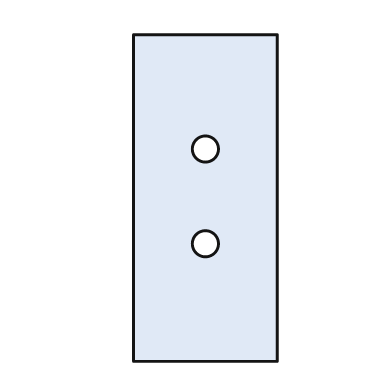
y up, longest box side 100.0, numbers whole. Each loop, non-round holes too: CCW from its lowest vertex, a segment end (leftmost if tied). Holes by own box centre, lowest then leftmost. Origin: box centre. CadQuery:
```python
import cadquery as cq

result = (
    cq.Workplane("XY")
    .moveTo(-22.0, -50.0)
    .lineTo(22.0, -50.0)
    .lineTo(22.0, 50.0)
    .lineTo(-22.0, 50.0)
    .close()
    .moveTo(0.0, -14.0)
    .circle(4.0)
    .moveTo(0.0, 15.0)
    .circle(4.0)
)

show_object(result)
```